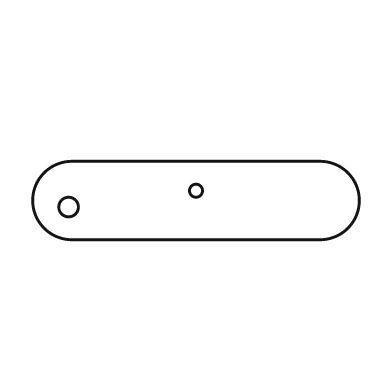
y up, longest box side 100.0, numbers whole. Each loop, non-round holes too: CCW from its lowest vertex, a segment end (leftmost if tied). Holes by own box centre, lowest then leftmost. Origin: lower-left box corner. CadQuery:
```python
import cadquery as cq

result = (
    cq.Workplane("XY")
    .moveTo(12.0, 0.0)
    .lineTo(88.0, 0.0)
    .threePointArc((100.0, 12.0), (88.0, 24.0))
    .lineTo(12.0, 24.0)
    .threePointArc((0.0, 12.0), (12.0, 0.0))
    .close()
    .moveTo(11.0, 10.0)
    .circle(3.0)
    .moveTo(50.0, 15.0)
    .circle(2.0)
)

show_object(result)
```